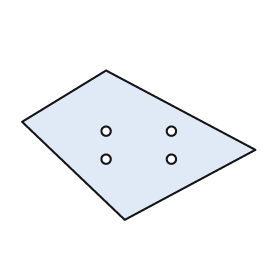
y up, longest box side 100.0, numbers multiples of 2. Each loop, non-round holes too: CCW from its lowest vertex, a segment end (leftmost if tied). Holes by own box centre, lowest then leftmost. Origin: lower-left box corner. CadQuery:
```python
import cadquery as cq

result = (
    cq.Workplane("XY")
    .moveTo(44.0, 0.0)
    .lineTo(100.0, 30.0)
    .lineTo(36.0, 64.0)
    .lineTo(0.0, 42.0)
    .close()
    .moveTo(36.0, 26.0)
    .circle(2.0)
    .moveTo(64.0, 26.0)
    .circle(2.0)
    .moveTo(36.0, 38.0)
    .circle(2.0)
    .moveTo(64.0, 38.0)
    .circle(2.0)
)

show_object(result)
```